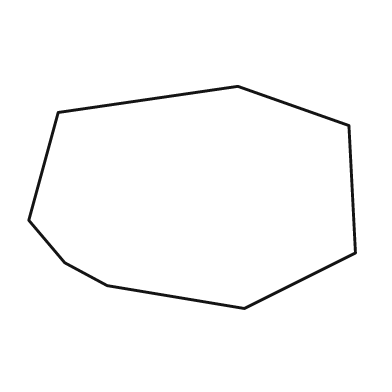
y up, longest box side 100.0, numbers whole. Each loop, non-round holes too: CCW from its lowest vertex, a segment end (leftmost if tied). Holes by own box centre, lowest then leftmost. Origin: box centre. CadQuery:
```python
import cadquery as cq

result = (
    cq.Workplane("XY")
    .moveTo(16.0, -34.0)
    .lineTo(50.0, -17.0)
    .lineTo(48.0, 22.0)
    .lineTo(14.0, 34.0)
    .lineTo(-41.0, 26.0)
    .lineTo(-50.0, -7.0)
    .lineTo(-39.0, -20.0)
    .lineTo(-26.0, -27.0)
    .close()
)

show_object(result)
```